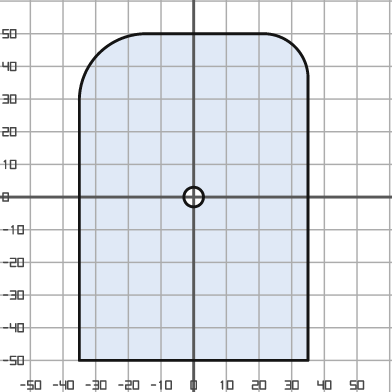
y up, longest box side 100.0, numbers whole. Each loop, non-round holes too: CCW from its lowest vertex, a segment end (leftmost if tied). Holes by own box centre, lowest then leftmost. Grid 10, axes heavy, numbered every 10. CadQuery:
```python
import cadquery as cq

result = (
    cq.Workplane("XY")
    .moveTo(-35.0, -50.0)
    .lineTo(35.0, -50.0)
    .lineTo(35.0, 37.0)
    .threePointArc((31.0, 46.0), (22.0, 50.0))
    .lineTo(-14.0, 50.0)
    .threePointArc((-29.0, 44.0), (-35.0, 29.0))
    .close()
    .moveTo(0.0, 0.0)
    .circle(3.0)
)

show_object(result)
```